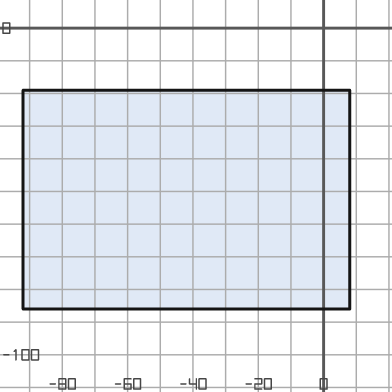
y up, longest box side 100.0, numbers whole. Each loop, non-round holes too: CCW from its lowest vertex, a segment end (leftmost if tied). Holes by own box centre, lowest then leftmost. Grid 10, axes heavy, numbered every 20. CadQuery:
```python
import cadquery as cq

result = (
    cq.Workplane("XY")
    .moveTo(-92.0, -86.0)
    .lineTo(8.0, -86.0)
    .lineTo(8.0, -19.0)
    .lineTo(-92.0, -19.0)
    .close()
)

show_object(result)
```